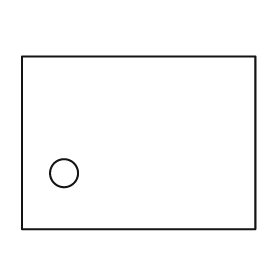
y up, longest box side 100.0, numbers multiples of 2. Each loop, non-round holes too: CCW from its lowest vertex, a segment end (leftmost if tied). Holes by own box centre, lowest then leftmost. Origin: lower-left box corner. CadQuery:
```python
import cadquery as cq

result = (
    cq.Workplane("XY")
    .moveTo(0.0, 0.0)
    .lineTo(100.0, 0.0)
    .lineTo(100.0, 74.0)
    .lineTo(0.0, 74.0)
    .close()
    .moveTo(18.0, 24.0)
    .circle(6.0)
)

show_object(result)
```